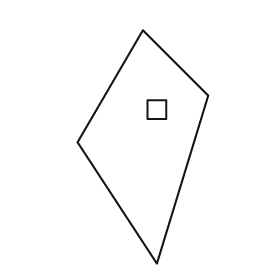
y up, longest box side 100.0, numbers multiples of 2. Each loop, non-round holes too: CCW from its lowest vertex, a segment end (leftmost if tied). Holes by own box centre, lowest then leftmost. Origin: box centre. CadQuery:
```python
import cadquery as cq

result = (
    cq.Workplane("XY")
    .moveTo(6.0, -50.0)
    .lineTo(28.0, 22.0)
    .lineTo(0.0, 50.0)
    .lineTo(-28.0, 2.0)
    .close()
    .moveTo(2.0, 12.0)
    .lineTo(10.0, 12.0)
    .lineTo(10.0, 20.0)
    .lineTo(2.0, 20.0)
    .close()
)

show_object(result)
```